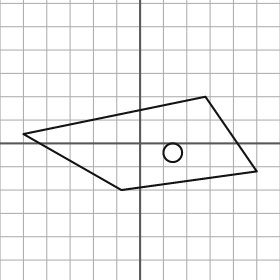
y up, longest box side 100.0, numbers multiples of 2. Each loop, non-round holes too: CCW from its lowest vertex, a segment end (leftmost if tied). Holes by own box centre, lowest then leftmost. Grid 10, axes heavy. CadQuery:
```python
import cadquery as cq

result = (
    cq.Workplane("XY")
    .moveTo(-8.0, -20.0)
    .lineTo(50.0, -12.0)
    .lineTo(28.0, 20.0)
    .lineTo(-50.0, 4.0)
    .close()
    .moveTo(14.0, -4.0)
    .circle(4.0)
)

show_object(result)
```